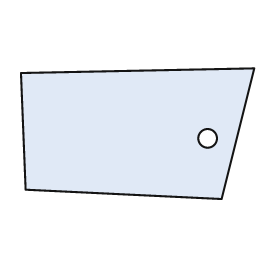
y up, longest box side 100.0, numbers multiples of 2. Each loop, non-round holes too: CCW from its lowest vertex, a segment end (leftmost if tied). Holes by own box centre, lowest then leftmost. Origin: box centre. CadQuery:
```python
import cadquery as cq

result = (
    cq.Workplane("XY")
    .moveTo(36.0, -28.0)
    .lineTo(50.0, 28.0)
    .lineTo(-50.0, 26.0)
    .lineTo(-48.0, -24.0)
    .close()
    .moveTo(30.0, -2.0)
    .circle(4.0)
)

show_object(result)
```